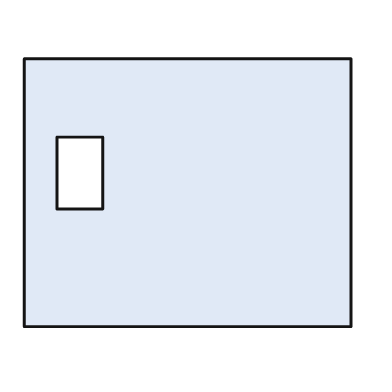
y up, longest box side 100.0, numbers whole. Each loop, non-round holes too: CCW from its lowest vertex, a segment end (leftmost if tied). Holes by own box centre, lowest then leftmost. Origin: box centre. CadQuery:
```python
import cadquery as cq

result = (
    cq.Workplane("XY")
    .moveTo(-50.0, -41.0)
    .lineTo(50.0, -41.0)
    .lineTo(50.0, 41.0)
    .lineTo(-50.0, 41.0)
    .close()
    .moveTo(-40.0, -5.0)
    .lineTo(-26.0, -5.0)
    .lineTo(-26.0, 17.0)
    .lineTo(-40.0, 17.0)
    .close()
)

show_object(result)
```